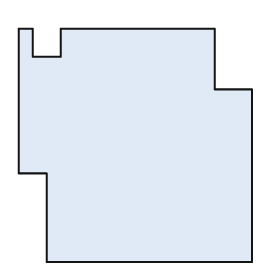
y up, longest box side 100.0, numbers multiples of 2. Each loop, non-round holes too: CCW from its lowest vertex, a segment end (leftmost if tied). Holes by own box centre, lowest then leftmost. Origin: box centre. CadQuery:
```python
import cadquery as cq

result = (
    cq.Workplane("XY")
    .moveTo(-38.0, -50.0)
    .lineTo(50.0, -50.0)
    .lineTo(50.0, 24.0)
    .lineTo(34.0, 24.0)
    .lineTo(34.0, 50.0)
    .lineTo(-32.0, 50.0)
    .lineTo(-32.0, 38.0)
    .lineTo(-44.0, 38.0)
    .lineTo(-44.0, 50.0)
    .lineTo(-50.0, 50.0)
    .lineTo(-50.0, -12.0)
    .lineTo(-38.0, -12.0)
    .close()
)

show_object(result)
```